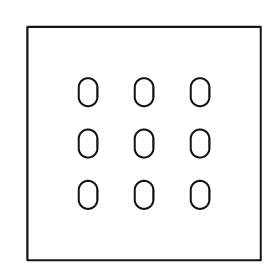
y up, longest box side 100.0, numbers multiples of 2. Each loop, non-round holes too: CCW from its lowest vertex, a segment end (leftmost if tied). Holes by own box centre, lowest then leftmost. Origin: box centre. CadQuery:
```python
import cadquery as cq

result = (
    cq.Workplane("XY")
    .moveTo(-50.0, -50.0)
    .lineTo(50.0, -50.0)
    .lineTo(50.0, 50.0)
    .lineTo(-50.0, 50.0)
    .close()
    .moveTo(-28.0, -24.0)
    .threePointArc((-24.0, -28.0), (-20.0, -24.0))
    .lineTo(-20.0, -20.0)
    .threePointArc((-24.0, -16.0), (-28.0, -20.0))
    .close()
    .moveTo(-4.0, -24.0)
    .threePointArc((0.0, -28.0), (4.0, -24.0))
    .lineTo(4.0, -20.0)
    .threePointArc((0.0, -16.0), (-4.0, -20.0))
    .close()
    .moveTo(20.0, -24.0)
    .threePointArc((24.0, -28.0), (28.0, -24.0))
    .lineTo(28.0, -20.0)
    .threePointArc((24.0, -16.0), (20.0, -20.0))
    .close()
    .moveTo(-28.0, -2.0)
    .threePointArc((-24.0, -6.0), (-20.0, -2.0))
    .lineTo(-20.0, 2.0)
    .threePointArc((-24.0, 6.0), (-28.0, 2.0))
    .close()
    .moveTo(-4.0, -2.0)
    .threePointArc((0.0, -6.0), (4.0, -2.0))
    .lineTo(4.0, 2.0)
    .threePointArc((0.0, 6.0), (-4.0, 2.0))
    .close()
    .moveTo(20.0, -2.0)
    .threePointArc((24.0, -6.0), (28.0, -2.0))
    .lineTo(28.0, 2.0)
    .threePointArc((24.0, 6.0), (20.0, 2.0))
    .close()
    .moveTo(-28.0, 20.0)
    .threePointArc((-24.0, 16.0), (-20.0, 20.0))
    .lineTo(-20.0, 24.0)
    .threePointArc((-24.0, 28.0), (-28.0, 24.0))
    .close()
    .moveTo(-4.0, 20.0)
    .threePointArc((0.0, 16.0), (4.0, 20.0))
    .lineTo(4.0, 24.0)
    .threePointArc((0.0, 28.0), (-4.0, 24.0))
    .close()
    .moveTo(20.0, 20.0)
    .threePointArc((24.0, 16.0), (28.0, 20.0))
    .lineTo(28.0, 24.0)
    .threePointArc((24.0, 28.0), (20.0, 24.0))
    .close()
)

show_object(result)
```